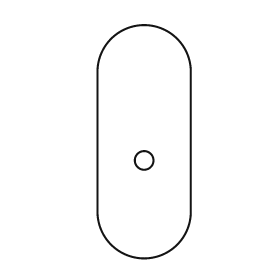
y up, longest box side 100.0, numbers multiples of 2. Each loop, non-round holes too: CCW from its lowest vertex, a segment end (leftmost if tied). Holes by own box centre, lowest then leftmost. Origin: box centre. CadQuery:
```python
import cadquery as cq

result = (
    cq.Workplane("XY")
    .moveTo(-20.0, -30.0)
    .threePointArc((0.0, -50.0), (20.0, -30.0))
    .lineTo(20.0, 30.0)
    .threePointArc((0.0, 50.0), (-20.0, 30.0))
    .close()
    .moveTo(0.0, -8.0)
    .circle(4.0)
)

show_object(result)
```